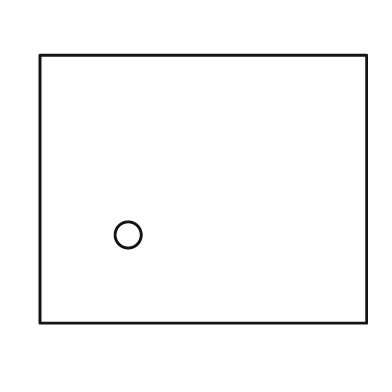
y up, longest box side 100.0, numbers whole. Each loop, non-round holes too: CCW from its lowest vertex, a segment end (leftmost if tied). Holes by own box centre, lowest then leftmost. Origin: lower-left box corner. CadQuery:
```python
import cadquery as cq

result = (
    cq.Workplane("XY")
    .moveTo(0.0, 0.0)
    .lineTo(100.0, 0.0)
    .lineTo(100.0, 82.0)
    .lineTo(0.0, 82.0)
    .close()
    .moveTo(27.0, 27.0)
    .circle(4.0)
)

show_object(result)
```